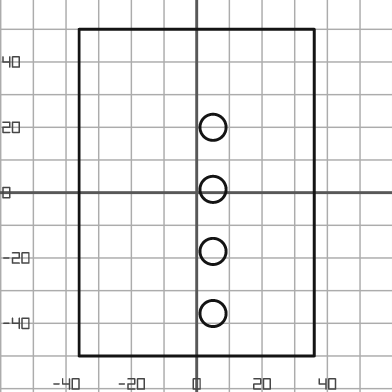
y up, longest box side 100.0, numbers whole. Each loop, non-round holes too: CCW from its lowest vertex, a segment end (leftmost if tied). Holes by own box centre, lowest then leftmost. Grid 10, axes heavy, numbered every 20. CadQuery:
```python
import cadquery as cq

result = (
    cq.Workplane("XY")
    .moveTo(-36.0, -50.0)
    .lineTo(36.0, -50.0)
    .lineTo(36.0, 50.0)
    .lineTo(-36.0, 50.0)
    .close()
    .moveTo(5.0, -37.0)
    .circle(4.0)
    .moveTo(5.0, -18.0)
    .circle(4.0)
    .moveTo(5.0, 1.0)
    .circle(4.0)
    .moveTo(5.0, 20.0)
    .circle(4.0)
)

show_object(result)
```